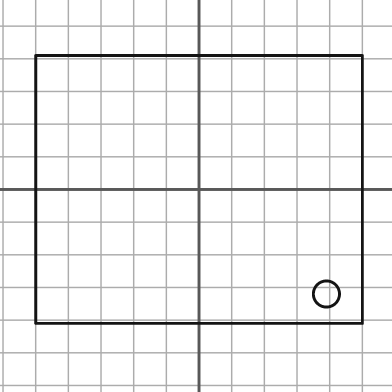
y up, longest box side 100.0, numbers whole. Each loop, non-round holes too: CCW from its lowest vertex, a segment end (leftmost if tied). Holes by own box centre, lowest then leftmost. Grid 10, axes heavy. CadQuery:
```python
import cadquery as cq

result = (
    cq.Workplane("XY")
    .moveTo(-50.0, -41.0)
    .lineTo(50.0, -41.0)
    .lineTo(50.0, 41.0)
    .lineTo(-50.0, 41.0)
    .close()
    .moveTo(39.0, -32.0)
    .circle(4.0)
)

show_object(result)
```